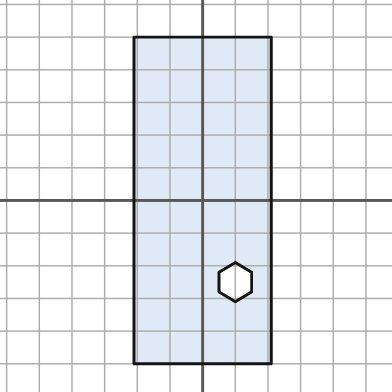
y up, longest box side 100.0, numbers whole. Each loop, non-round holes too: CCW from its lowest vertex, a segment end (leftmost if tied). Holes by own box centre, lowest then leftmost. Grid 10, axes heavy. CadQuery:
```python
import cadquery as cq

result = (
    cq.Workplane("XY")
    .moveTo(-21.0, -50.0)
    .lineTo(21.0, -50.0)
    .lineTo(21.0, 50.0)
    .lineTo(-21.0, 50.0)
    .close()
    .moveTo(10.0, -31.0)
    .lineTo(15.0, -28.0)
    .lineTo(15.0, -22.0)
    .lineTo(10.0, -19.0)
    .lineTo(5.0, -22.0)
    .lineTo(5.0, -28.0)
    .close()
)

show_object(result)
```